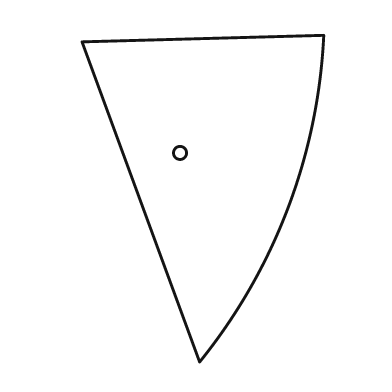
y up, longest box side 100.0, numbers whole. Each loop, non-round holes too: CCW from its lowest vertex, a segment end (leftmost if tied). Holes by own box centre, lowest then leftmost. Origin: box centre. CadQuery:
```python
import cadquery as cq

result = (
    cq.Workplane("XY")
    .moveTo(-1.0, -50.0)
    .threePointArc((26.0, -3.0), (37.0, 50.0))
    .lineTo(-37.0, 48.0)
    .close()
    .moveTo(-7.0, 14.0)
    .circle(2.0)
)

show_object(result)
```